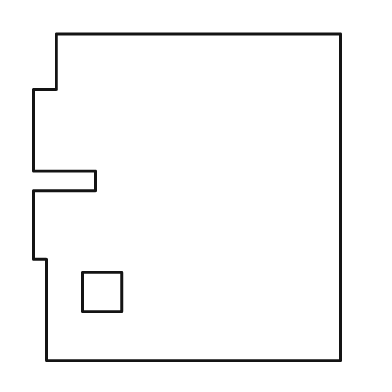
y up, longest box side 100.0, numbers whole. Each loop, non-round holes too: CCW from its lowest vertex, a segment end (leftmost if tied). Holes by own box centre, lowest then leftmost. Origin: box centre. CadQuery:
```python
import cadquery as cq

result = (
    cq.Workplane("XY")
    .moveTo(-43.0, -50.0)
    .lineTo(47.0, -50.0)
    .lineTo(47.0, 50.0)
    .lineTo(-40.0, 50.0)
    .lineTo(-40.0, 33.0)
    .lineTo(-47.0, 33.0)
    .lineTo(-47.0, 8.0)
    .lineTo(-28.0, 8.0)
    .lineTo(-28.0, 2.0)
    .lineTo(-47.0, 2.0)
    .lineTo(-47.0, -19.0)
    .lineTo(-43.0, -19.0)
    .close()
    .moveTo(-32.0, -35.0)
    .lineTo(-20.0, -35.0)
    .lineTo(-20.0, -23.0)
    .lineTo(-32.0, -23.0)
    .close()
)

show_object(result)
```